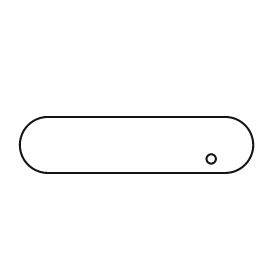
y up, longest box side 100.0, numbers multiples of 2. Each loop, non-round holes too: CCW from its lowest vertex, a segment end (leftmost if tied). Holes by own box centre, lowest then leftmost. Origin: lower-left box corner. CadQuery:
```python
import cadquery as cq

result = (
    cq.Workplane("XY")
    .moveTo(12.0, 0.0)
    .lineTo(88.0, 0.0)
    .threePointArc((100.0, 12.0), (88.0, 24.0))
    .lineTo(12.0, 24.0)
    .threePointArc((0.0, 12.0), (12.0, 0.0))
    .close()
    .moveTo(82.0, 6.0)
    .circle(2.0)
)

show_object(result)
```